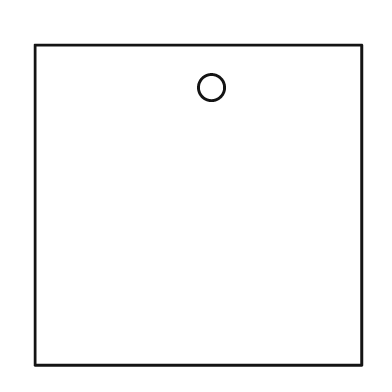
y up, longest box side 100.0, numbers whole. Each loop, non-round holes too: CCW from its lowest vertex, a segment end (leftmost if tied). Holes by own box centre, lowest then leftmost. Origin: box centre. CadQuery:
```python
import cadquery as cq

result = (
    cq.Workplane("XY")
    .moveTo(-50.0, -49.0)
    .lineTo(50.0, -49.0)
    .lineTo(50.0, 49.0)
    .lineTo(-50.0, 49.0)
    .close()
    .moveTo(4.0, 36.0)
    .circle(4.0)
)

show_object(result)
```